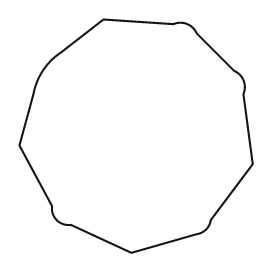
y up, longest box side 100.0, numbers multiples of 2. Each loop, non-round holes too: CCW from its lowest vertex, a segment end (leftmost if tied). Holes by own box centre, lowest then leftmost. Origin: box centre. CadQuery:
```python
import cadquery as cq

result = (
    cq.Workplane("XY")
    .moveTo(-2.0, -50.0)
    .lineTo(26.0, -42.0)
    .threePointArc((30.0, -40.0), (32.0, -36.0))
    .lineTo(50.0, -12.0)
    .lineTo(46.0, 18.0)
    .threePointArc((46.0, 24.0), (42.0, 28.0))
    .lineTo(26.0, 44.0)
    .threePointArc((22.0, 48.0), (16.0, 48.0))
    .lineTo(-14.0, 50.0)
    .lineTo(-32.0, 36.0)
    .threePointArc((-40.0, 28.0), (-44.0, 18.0))
    .lineTo(-50.0, -4.0)
    .lineTo(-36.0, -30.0)
    .threePointArc((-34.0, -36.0), (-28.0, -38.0))
    .close()
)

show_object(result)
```